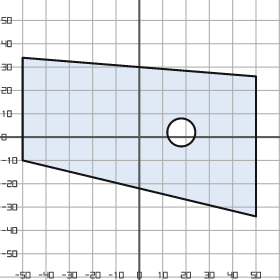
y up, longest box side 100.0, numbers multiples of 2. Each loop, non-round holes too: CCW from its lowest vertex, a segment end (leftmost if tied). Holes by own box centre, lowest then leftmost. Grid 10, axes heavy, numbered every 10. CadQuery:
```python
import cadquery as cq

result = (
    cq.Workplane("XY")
    .moveTo(50.0, -34.0)
    .lineTo(50.0, 26.0)
    .lineTo(-50.0, 34.0)
    .lineTo(-50.0, -10.0)
    .close()
    .moveTo(18.0, 2.0)
    .circle(6.0)
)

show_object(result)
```